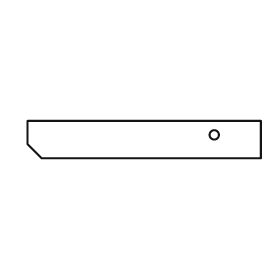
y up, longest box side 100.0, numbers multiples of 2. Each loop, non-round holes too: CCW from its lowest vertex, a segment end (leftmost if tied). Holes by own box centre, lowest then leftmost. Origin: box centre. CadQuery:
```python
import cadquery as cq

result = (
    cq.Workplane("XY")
    .moveTo(-44.0, -8.0)
    .lineTo(50.0, -8.0)
    .lineTo(50.0, 8.0)
    .lineTo(-50.0, 8.0)
    .lineTo(-50.0, -2.0)
    .close()
    .moveTo(30.0, 2.0)
    .circle(2.0)
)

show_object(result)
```